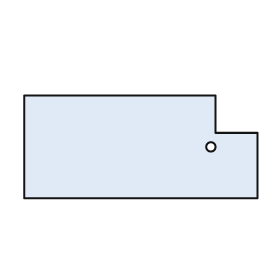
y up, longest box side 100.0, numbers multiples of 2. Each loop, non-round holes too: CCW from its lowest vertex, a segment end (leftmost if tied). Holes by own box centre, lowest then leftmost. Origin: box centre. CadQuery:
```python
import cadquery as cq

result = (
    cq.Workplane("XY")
    .moveTo(-50.0, -22.0)
    .lineTo(50.0, -22.0)
    .lineTo(50.0, 6.0)
    .lineTo(32.0, 6.0)
    .lineTo(32.0, 22.0)
    .lineTo(-50.0, 22.0)
    .close()
    .moveTo(30.0, 0.0)
    .circle(2.0)
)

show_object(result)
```